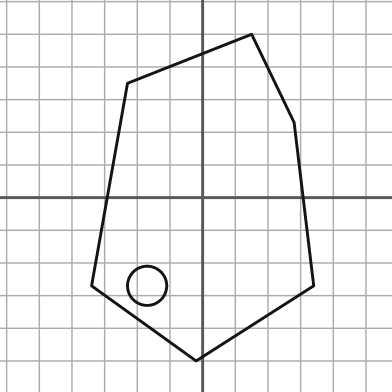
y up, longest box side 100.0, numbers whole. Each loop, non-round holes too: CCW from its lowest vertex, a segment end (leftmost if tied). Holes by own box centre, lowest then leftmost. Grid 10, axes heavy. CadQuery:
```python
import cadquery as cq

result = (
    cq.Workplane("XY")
    .moveTo(-2.0, -50.0)
    .lineTo(34.0, -27.0)
    .lineTo(28.0, 23.0)
    .lineTo(15.0, 50.0)
    .lineTo(-23.0, 35.0)
    .lineTo(-34.0, -27.0)
    .close()
    .moveTo(-17.0, -27.0)
    .circle(6.0)
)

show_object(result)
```